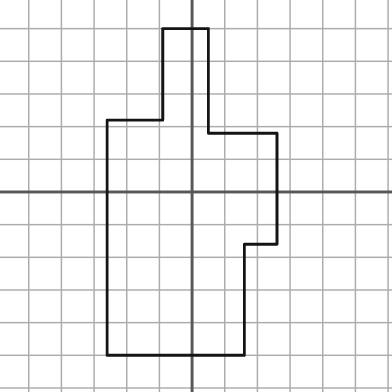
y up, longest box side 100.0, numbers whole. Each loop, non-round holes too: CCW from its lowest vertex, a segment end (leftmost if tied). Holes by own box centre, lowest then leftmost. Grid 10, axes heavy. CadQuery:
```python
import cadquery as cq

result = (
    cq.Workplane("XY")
    .moveTo(-26.0, -50.0)
    .lineTo(16.0, -50.0)
    .lineTo(16.0, -16.0)
    .lineTo(26.0, -16.0)
    .lineTo(26.0, 18.0)
    .lineTo(5.0, 18.0)
    .lineTo(5.0, 50.0)
    .lineTo(-9.0, 50.0)
    .lineTo(-9.0, 22.0)
    .lineTo(-26.0, 22.0)
    .close()
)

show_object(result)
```